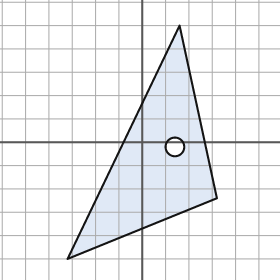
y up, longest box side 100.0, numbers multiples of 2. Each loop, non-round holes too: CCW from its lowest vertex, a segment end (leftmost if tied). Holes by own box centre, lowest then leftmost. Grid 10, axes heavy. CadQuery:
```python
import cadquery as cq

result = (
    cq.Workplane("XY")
    .moveTo(-32.0, -50.0)
    .lineTo(32.0, -24.0)
    .lineTo(16.0, 50.0)
    .close()
    .moveTo(14.0, -2.0)
    .circle(4.0)
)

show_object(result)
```